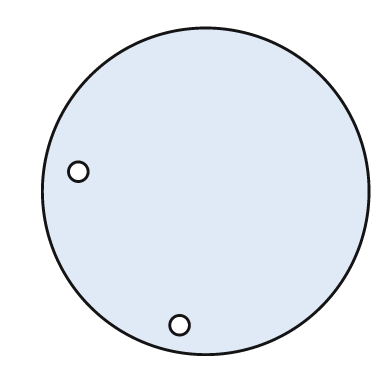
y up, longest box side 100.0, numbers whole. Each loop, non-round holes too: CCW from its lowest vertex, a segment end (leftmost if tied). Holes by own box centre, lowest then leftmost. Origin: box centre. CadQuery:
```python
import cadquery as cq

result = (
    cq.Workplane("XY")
    .moveTo(0.0, 0.0)
    .circle(50.0)
    .moveTo(-8.0, -41.0)
    .circle(3.0)
    .moveTo(-39.0, 6.0)
    .circle(3.0)
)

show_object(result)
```